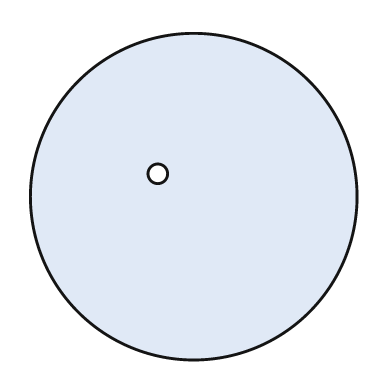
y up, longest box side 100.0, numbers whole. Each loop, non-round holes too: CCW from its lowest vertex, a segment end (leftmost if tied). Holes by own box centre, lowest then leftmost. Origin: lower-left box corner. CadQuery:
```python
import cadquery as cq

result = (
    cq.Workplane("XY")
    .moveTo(50.0, 50.0)
    .circle(50.0)
    .moveTo(39.0, 57.0)
    .circle(3.0)
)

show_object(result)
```